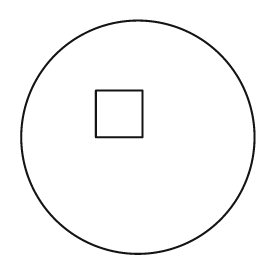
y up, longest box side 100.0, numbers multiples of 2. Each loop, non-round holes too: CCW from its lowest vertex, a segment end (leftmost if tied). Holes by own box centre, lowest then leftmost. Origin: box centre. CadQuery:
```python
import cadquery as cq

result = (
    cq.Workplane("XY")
    .moveTo(0.0, 0.0)
    .circle(50.0)
    .moveTo(-18.0, 0.0)
    .lineTo(2.0, 0.0)
    .lineTo(2.0, 20.0)
    .lineTo(-18.0, 20.0)
    .close()
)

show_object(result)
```